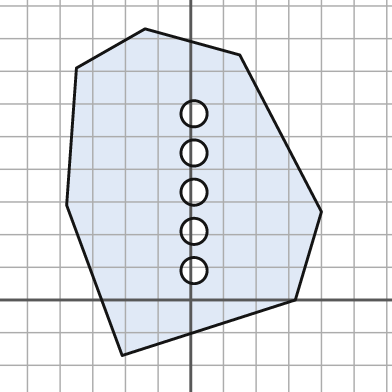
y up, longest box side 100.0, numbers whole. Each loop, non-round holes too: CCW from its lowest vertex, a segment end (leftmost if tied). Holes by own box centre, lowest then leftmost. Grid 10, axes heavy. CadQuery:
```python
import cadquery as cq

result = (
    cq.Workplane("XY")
    .moveTo(-21.0, -17.0)
    .lineTo(32.0, 0.0)
    .lineTo(40.0, 27.0)
    .lineTo(15.0, 75.0)
    .lineTo(-14.0, 83.0)
    .lineTo(-35.0, 71.0)
    .lineTo(-38.0, 29.0)
    .close()
    .moveTo(1.0, 9.0)
    .circle(4.0)
    .moveTo(1.0, 21.0)
    .circle(4.0)
    .moveTo(1.0, 33.0)
    .circle(4.0)
    .moveTo(1.0, 45.0)
    .circle(4.0)
    .moveTo(1.0, 57.0)
    .circle(4.0)
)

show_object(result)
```